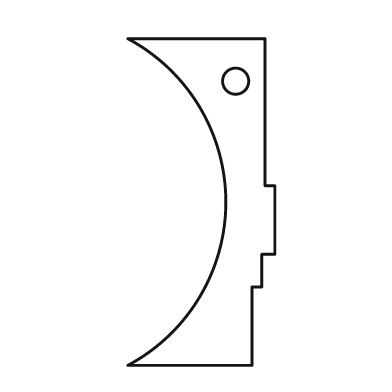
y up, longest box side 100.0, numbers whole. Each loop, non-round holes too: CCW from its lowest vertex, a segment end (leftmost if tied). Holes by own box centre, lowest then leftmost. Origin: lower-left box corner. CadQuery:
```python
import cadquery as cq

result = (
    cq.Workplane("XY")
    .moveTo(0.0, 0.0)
    .lineTo(38.0, 0.0)
    .lineTo(38.0, 24.0)
    .lineTo(41.0, 24.0)
    .lineTo(41.0, 34.0)
    .lineTo(45.0, 34.0)
    .lineTo(45.0, 55.0)
    .lineTo(42.0, 55.0)
    .lineTo(42.0, 100.0)
    .lineTo(0.0, 100.0)
    .threePointArc((30.0, 50.0), (0.0, 0.0))
    .close()
    .moveTo(33.0, 87.0)
    .circle(4.0)
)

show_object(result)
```